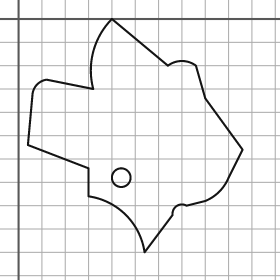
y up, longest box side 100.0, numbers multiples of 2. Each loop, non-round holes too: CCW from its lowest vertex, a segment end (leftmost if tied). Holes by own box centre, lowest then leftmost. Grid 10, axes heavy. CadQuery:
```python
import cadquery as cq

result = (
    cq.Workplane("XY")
    .moveTo(54.0, -100.0)
    .lineTo(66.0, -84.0)
    .threePointArc((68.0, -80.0), (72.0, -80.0))
    .lineTo(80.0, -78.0)
    .threePointArc((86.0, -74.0), (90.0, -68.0))
    .lineTo(96.0, -56.0)
    .lineTo(80.0, -34.0)
    .lineTo(76.0, -20.0)
    .threePointArc((70.0, -18.0), (64.0, -20.0))
    .lineTo(40.0, 0.0)
    .threePointArc((32.0, -14.0), (32.0, -30.0))
    .lineTo(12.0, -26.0)
    .threePointArc((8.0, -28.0), (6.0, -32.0))
    .lineTo(4.0, -54.0)
    .lineTo(30.0, -64.0)
    .lineTo(30.0, -76.0)
    .threePointArc((46.0, -84.0), (54.0, -100.0))
    .close()
    .moveTo(44.0, -68.0)
    .circle(4.0)
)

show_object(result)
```